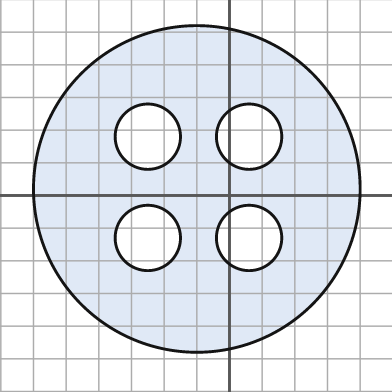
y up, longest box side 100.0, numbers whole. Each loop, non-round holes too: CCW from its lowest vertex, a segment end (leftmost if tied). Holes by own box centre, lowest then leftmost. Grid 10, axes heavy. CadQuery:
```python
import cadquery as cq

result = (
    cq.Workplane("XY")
    .moveTo(-10.0, 2.0)
    .circle(50.0)
    .moveTo(-25.0, -13.0)
    .circle(10.0)
    .moveTo(6.0, -13.0)
    .circle(10.0)
    .moveTo(-25.0, 18.0)
    .circle(10.0)
    .moveTo(6.0, 18.0)
    .circle(10.0)
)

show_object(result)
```